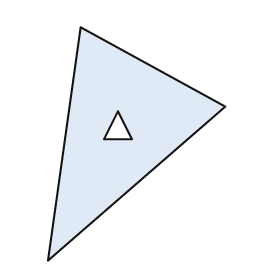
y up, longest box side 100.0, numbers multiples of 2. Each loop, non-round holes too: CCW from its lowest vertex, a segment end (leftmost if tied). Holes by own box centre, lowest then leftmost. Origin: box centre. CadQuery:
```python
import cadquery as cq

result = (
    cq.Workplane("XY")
    .moveTo(-38.0, -50.0)
    .lineTo(38.0, 16.0)
    .lineTo(-24.0, 50.0)
    .close()
    .moveTo(-14.0, 2.0)
    .lineTo(-2.0, 2.0)
    .lineTo(-8.0, 14.0)
    .close()
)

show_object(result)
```